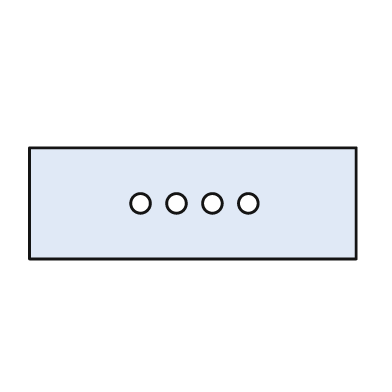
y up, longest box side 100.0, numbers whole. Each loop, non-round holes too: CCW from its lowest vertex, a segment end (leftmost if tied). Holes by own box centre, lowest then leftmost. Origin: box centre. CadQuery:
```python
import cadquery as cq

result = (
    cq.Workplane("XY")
    .moveTo(-50.0, -17.0)
    .lineTo(50.0, -17.0)
    .lineTo(50.0, 17.0)
    .lineTo(-50.0, 17.0)
    .close()
    .moveTo(-16.0, 0.0)
    .circle(3.0)
    .moveTo(-5.0, 0.0)
    .circle(3.0)
    .moveTo(6.0, 0.0)
    .circle(3.0)
    .moveTo(17.0, 0.0)
    .circle(3.0)
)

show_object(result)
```